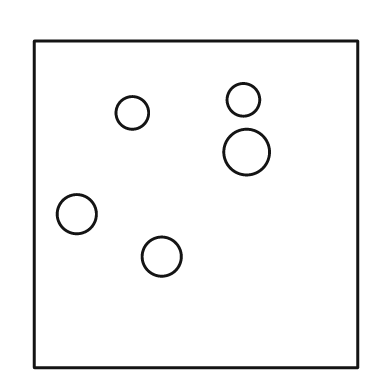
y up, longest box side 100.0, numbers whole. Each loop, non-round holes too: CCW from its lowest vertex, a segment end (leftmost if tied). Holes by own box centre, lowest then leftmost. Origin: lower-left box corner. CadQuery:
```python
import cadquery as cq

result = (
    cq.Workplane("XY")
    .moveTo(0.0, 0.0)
    .lineTo(99.0, 0.0)
    .lineTo(99.0, 100.0)
    .lineTo(0.0, 100.0)
    .close()
    .moveTo(39.0, 34.0)
    .circle(6.0)
    .moveTo(13.0, 47.0)
    .circle(6.0)
    .moveTo(65.0, 66.0)
    .circle(7.0)
    .moveTo(30.0, 78.0)
    .circle(5.0)
    .moveTo(64.0, 82.0)
    .circle(5.0)
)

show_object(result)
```